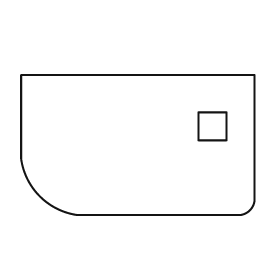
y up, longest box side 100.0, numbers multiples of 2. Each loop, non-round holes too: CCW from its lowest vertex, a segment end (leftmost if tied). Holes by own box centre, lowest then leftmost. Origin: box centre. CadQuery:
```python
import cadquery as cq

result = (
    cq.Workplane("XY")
    .moveTo(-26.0, -30.0)
    .lineTo(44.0, -30.0)
    .threePointArc((48.0, -28.0), (50.0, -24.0))
    .lineTo(50.0, 30.0)
    .lineTo(-50.0, 30.0)
    .lineTo(-50.0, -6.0)
    .threePointArc((-42.0, -22.0), (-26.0, -30.0))
    .close()
    .moveTo(26.0, 2.0)
    .lineTo(38.0, 2.0)
    .lineTo(38.0, 14.0)
    .lineTo(26.0, 14.0)
    .close()
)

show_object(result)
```